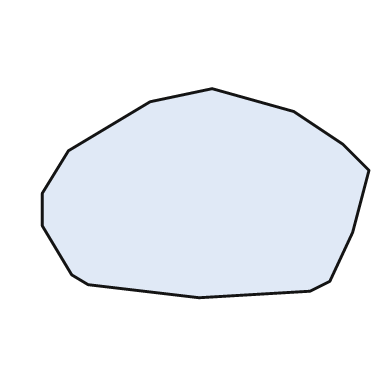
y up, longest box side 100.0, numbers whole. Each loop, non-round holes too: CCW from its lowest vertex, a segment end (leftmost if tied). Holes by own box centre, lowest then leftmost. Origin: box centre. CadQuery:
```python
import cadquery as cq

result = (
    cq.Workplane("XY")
    .moveTo(-2.0, -32.0)
    .lineTo(32.0, -30.0)
    .lineTo(38.0, -27.0)
    .lineTo(45.0, -12.0)
    .lineTo(50.0, 7.0)
    .lineTo(42.0, 15.0)
    .lineTo(27.0, 25.0)
    .lineTo(2.0, 32.0)
    .lineTo(-17.0, 28.0)
    .lineTo(-42.0, 13.0)
    .lineTo(-50.0, 0.0)
    .lineTo(-50.0, -10.0)
    .lineTo(-41.0, -25.0)
    .lineTo(-36.0, -28.0)
    .close()
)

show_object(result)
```